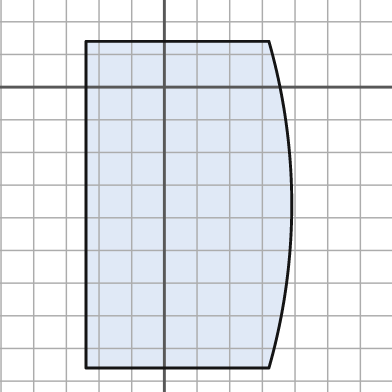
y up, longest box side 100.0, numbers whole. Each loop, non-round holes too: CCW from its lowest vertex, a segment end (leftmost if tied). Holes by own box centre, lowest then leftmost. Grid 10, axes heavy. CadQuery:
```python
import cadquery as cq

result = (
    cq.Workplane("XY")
    .moveTo(-24.0, -86.0)
    .lineTo(32.0, -86.0)
    .threePointArc((39.0, -36.0), (32.0, 14.0))
    .lineTo(-24.0, 14.0)
    .close()
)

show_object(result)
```